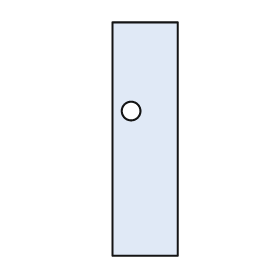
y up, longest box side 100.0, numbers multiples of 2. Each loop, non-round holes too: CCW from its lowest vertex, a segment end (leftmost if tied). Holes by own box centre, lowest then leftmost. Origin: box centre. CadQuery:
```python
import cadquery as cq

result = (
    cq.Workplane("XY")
    .moveTo(-14.0, -50.0)
    .lineTo(14.0, -50.0)
    .lineTo(14.0, 50.0)
    .lineTo(-14.0, 50.0)
    .close()
    .moveTo(-6.0, 12.0)
    .circle(4.0)
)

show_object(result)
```